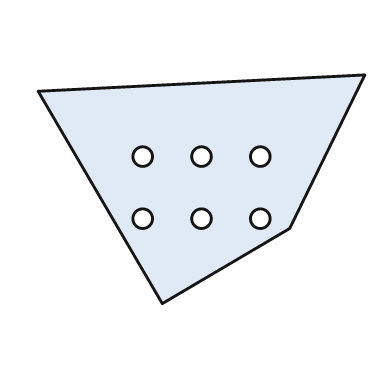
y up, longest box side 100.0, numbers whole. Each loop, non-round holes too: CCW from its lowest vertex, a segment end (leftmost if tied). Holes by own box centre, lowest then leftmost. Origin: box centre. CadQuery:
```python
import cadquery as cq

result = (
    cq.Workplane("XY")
    .moveTo(-12.0, -35.0)
    .lineTo(27.0, -12.0)
    .lineTo(50.0, 35.0)
    .lineTo(-50.0, 30.0)
    .close()
    .moveTo(-18.0, -9.0)
    .circle(3.0)
    .moveTo(0.0, -9.0)
    .circle(3.0)
    .moveTo(18.0, -9.0)
    .circle(3.0)
    .moveTo(-18.0, 10.0)
    .circle(3.0)
    .moveTo(0.0, 10.0)
    .circle(3.0)
    .moveTo(18.0, 10.0)
    .circle(3.0)
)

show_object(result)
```